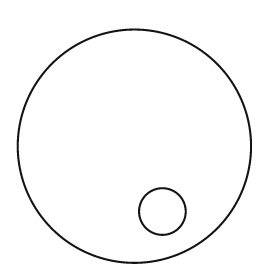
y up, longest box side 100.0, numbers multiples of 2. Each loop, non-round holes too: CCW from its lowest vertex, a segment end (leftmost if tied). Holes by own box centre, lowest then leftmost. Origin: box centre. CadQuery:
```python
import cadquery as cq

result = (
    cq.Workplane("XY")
    .moveTo(0.0, 0.0)
    .circle(50.0)
    .moveTo(12.0, -28.0)
    .circle(10.0)
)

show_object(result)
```